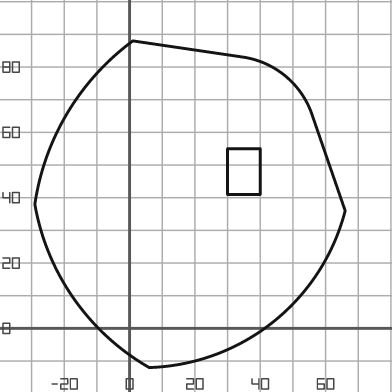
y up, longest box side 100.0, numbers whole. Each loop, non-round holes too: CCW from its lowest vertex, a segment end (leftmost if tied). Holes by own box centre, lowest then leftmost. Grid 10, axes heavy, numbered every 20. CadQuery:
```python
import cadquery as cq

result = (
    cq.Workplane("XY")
    .moveTo(6.0, -12.0)
    .threePointArc((44.0, 2.0), (66.0, 36.0))
    .lineTo(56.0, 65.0)
    .threePointArc((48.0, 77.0), (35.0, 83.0))
    .lineTo(1.0, 88.0)
    .threePointArc((-19.0, 66.0), (-29.0, 38.0))
    .threePointArc((-17.0, 9.0), (6.0, -12.0))
    .close()
    .moveTo(30.0, 41.0)
    .lineTo(40.0, 41.0)
    .lineTo(40.0, 55.0)
    .lineTo(30.0, 55.0)
    .close()
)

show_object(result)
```